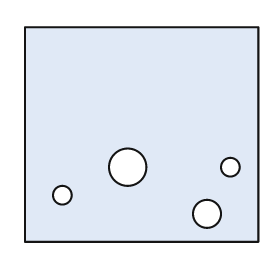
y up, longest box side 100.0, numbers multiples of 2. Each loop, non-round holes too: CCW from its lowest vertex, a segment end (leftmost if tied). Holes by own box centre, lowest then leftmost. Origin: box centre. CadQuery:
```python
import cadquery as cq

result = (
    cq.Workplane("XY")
    .moveTo(-50.0, -46.0)
    .lineTo(50.0, -46.0)
    .lineTo(50.0, 46.0)
    .lineTo(-50.0, 46.0)
    .close()
    .moveTo(28.0, -34.0)
    .circle(6.0)
    .moveTo(-34.0, -26.0)
    .circle(4.0)
    .moveTo(-6.0, -14.0)
    .circle(8.0)
    .moveTo(38.0, -14.0)
    .circle(4.0)
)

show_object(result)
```